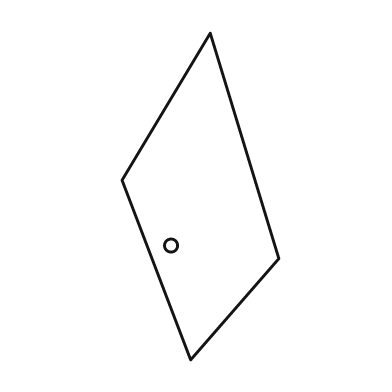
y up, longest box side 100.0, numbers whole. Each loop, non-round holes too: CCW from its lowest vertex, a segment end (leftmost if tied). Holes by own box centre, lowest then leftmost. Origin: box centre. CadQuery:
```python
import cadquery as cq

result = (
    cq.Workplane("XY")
    .moveTo(-3.0, -50.0)
    .lineTo(24.0, -19.0)
    .lineTo(3.0, 50.0)
    .lineTo(-24.0, 5.0)
    .close()
    .moveTo(-9.0, -15.0)
    .circle(2.0)
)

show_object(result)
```